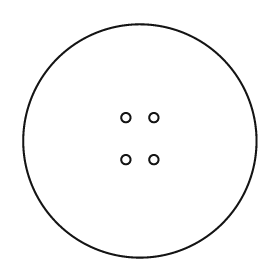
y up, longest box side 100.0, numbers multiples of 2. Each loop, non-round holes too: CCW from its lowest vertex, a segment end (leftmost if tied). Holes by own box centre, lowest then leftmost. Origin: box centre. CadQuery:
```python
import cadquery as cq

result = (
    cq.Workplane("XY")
    .moveTo(0.0, 0.0)
    .circle(50.0)
    .moveTo(-6.0, -8.0)
    .circle(2.0)
    .moveTo(6.0, -8.0)
    .circle(2.0)
    .moveTo(-6.0, 10.0)
    .circle(2.0)
    .moveTo(6.0, 10.0)
    .circle(2.0)
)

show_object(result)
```